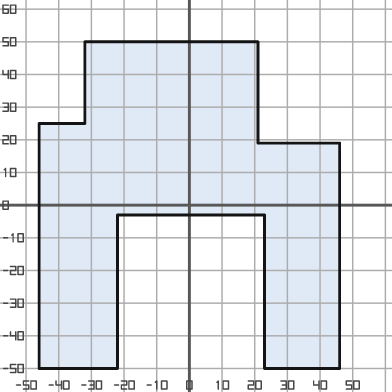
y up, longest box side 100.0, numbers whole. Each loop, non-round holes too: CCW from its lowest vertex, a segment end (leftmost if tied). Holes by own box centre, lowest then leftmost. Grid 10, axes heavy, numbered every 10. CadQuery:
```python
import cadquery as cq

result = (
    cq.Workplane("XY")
    .moveTo(-46.0, -50.0)
    .lineTo(-22.0, -50.0)
    .lineTo(-22.0, -3.0)
    .lineTo(23.0, -3.0)
    .lineTo(23.0, -50.0)
    .lineTo(46.0, -50.0)
    .lineTo(46.0, 19.0)
    .lineTo(21.0, 19.0)
    .lineTo(21.0, 50.0)
    .lineTo(-32.0, 50.0)
    .lineTo(-32.0, 25.0)
    .lineTo(-46.0, 25.0)
    .close()
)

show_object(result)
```